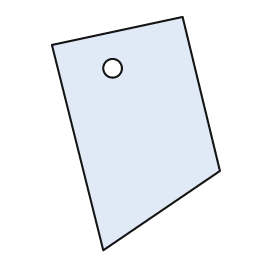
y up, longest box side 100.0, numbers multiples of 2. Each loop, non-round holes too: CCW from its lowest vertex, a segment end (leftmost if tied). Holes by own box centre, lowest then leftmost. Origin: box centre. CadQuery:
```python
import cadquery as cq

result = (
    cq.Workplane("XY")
    .moveTo(-14.0, -50.0)
    .lineTo(36.0, -16.0)
    .lineTo(20.0, 50.0)
    .lineTo(-36.0, 38.0)
    .close()
    .moveTo(-10.0, 28.0)
    .circle(4.0)
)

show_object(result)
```